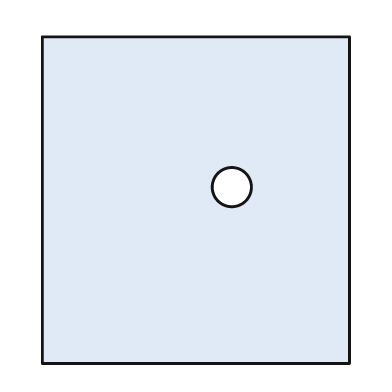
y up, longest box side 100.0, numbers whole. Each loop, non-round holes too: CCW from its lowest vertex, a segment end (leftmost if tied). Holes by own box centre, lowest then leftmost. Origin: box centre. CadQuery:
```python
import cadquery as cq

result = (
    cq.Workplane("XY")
    .moveTo(-47.0, -50.0)
    .lineTo(47.0, -50.0)
    .lineTo(47.0, 50.0)
    .lineTo(-47.0, 50.0)
    .close()
    .moveTo(11.0, 4.0)
    .circle(6.0)
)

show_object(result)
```